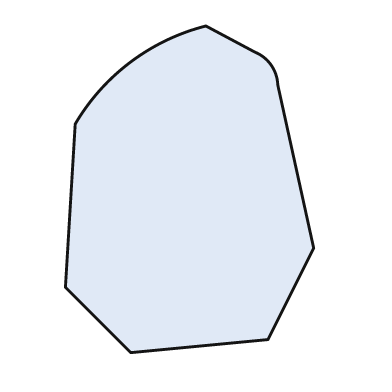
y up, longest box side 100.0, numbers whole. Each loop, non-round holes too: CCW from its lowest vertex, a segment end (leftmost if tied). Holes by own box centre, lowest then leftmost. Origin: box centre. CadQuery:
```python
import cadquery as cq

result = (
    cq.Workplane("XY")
    .moveTo(-18.0, -50.0)
    .lineTo(24.0, -46.0)
    .lineTo(38.0, -18.0)
    .lineTo(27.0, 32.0)
    .threePointArc((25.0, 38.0), (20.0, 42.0))
    .lineTo(5.0, 50.0)
    .threePointArc((-18.0, 39.0), (-35.0, 20.0))
    .lineTo(-38.0, -30.0)
    .close()
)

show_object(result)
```